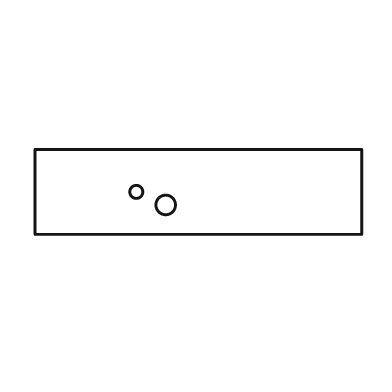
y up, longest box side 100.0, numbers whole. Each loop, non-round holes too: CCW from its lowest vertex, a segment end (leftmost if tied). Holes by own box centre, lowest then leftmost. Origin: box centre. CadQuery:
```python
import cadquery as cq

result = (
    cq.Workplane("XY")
    .moveTo(-50.0, -13.0)
    .lineTo(50.0, -13.0)
    .lineTo(50.0, 13.0)
    .lineTo(-50.0, 13.0)
    .close()
    .moveTo(-10.0, -4.0)
    .circle(3.0)
    .moveTo(-19.0, 0.0)
    .circle(2.0)
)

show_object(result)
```